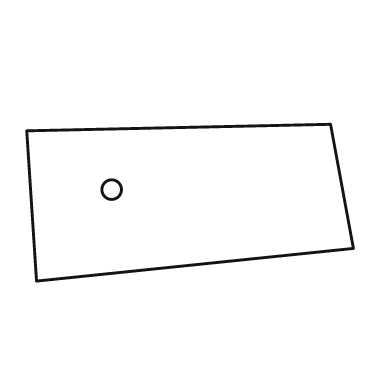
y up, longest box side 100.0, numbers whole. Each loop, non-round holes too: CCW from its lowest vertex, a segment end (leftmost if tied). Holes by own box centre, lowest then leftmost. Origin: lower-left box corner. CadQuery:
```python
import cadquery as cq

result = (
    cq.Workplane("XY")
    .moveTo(3.0, 0.0)
    .lineTo(100.0, 10.0)
    .lineTo(93.0, 48.0)
    .lineTo(0.0, 46.0)
    .close()
    .moveTo(26.0, 28.0)
    .circle(3.0)
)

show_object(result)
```